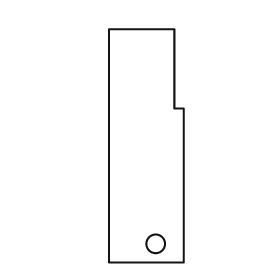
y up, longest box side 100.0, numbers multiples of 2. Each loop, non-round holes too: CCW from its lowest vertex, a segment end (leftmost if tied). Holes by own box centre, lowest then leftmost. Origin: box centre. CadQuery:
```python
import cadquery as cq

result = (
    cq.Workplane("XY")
    .moveTo(-16.0, -50.0)
    .lineTo(16.0, -50.0)
    .lineTo(16.0, 16.0)
    .lineTo(12.0, 16.0)
    .lineTo(12.0, 50.0)
    .lineTo(-16.0, 50.0)
    .close()
    .moveTo(4.0, -42.0)
    .circle(4.0)
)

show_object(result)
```